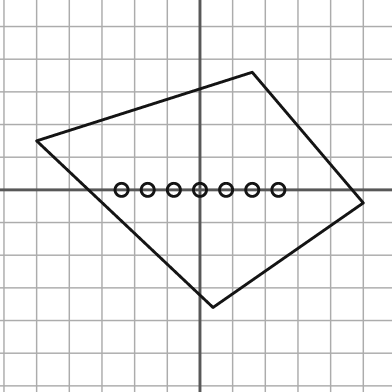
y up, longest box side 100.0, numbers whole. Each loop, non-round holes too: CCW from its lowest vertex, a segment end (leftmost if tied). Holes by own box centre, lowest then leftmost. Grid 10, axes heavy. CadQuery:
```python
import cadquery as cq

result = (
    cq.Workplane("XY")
    .moveTo(4.0, -36.0)
    .lineTo(50.0, -4.0)
    .lineTo(16.0, 36.0)
    .lineTo(-50.0, 15.0)
    .close()
    .moveTo(-24.0, 0.0)
    .circle(2.0)
    .moveTo(-16.0, 0.0)
    .circle(2.0)
    .moveTo(-8.0, 0.0)
    .circle(2.0)
    .moveTo(0.0, 0.0)
    .circle(2.0)
    .moveTo(8.0, 0.0)
    .circle(2.0)
    .moveTo(16.0, 0.0)
    .circle(2.0)
    .moveTo(24.0, 0.0)
    .circle(2.0)
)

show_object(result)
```